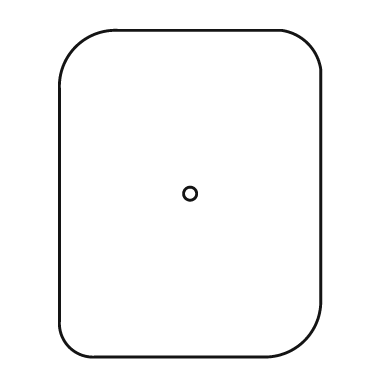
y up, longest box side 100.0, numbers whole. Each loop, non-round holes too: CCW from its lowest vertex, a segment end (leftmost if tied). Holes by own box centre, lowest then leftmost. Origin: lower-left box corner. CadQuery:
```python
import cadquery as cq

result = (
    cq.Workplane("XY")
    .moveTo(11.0, 0.0)
    .lineTo(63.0, 0.0)
    .threePointArc((75.0, 5.0), (80.0, 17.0))
    .lineTo(80.0, 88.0)
    .threePointArc((76.0, 96.0), (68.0, 100.0))
    .lineTo(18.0, 100.0)
    .threePointArc((5.0, 95.0), (0.0, 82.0))
    .lineTo(0.0, 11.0)
    .threePointArc((3.0, 3.0), (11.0, 0.0))
    .close()
    .moveTo(40.0, 50.0)
    .circle(2.0)
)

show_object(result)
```